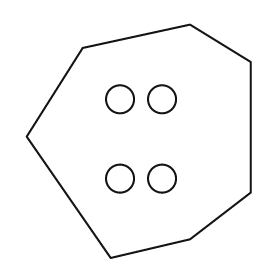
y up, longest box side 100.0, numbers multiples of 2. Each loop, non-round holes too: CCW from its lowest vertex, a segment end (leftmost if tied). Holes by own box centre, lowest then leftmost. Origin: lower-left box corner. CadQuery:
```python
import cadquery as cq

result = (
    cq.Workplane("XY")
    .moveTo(36.0, 0.0)
    .lineTo(70.0, 8.0)
    .lineTo(96.0, 28.0)
    .lineTo(96.0, 84.0)
    .lineTo(70.0, 100.0)
    .lineTo(24.0, 90.0)
    .lineTo(0.0, 52.0)
    .close()
    .moveTo(40.0, 34.0)
    .circle(6.0)
    .moveTo(58.0, 34.0)
    .circle(6.0)
    .moveTo(40.0, 68.0)
    .circle(6.0)
    .moveTo(58.0, 68.0)
    .circle(6.0)
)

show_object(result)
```